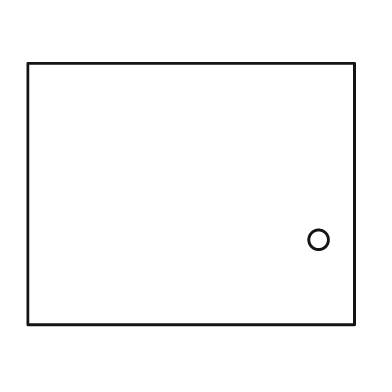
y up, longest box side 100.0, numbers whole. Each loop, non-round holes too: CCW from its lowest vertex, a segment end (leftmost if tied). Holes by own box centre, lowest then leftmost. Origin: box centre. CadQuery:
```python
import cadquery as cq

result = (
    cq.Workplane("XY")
    .moveTo(-50.0, -40.0)
    .lineTo(50.0, -40.0)
    .lineTo(50.0, 40.0)
    .lineTo(-50.0, 40.0)
    .close()
    .moveTo(39.0, -14.0)
    .circle(3.0)
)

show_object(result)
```